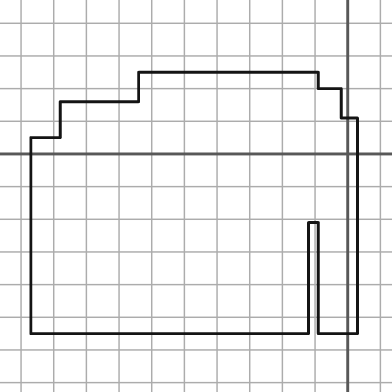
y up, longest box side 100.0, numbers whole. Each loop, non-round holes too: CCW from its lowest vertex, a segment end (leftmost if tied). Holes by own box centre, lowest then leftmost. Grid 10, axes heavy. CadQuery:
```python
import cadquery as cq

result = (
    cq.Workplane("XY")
    .moveTo(-97.0, -55.0)
    .lineTo(-12.0, -55.0)
    .lineTo(-12.0, -21.0)
    .lineTo(-9.0, -21.0)
    .lineTo(-9.0, -55.0)
    .lineTo(3.0, -55.0)
    .lineTo(3.0, 11.0)
    .lineTo(-2.0, 11.0)
    .lineTo(-2.0, 20.0)
    .lineTo(-9.0, 20.0)
    .lineTo(-9.0, 25.0)
    .lineTo(-64.0, 25.0)
    .lineTo(-64.0, 16.0)
    .lineTo(-88.0, 16.0)
    .lineTo(-88.0, 5.0)
    .lineTo(-97.0, 5.0)
    .close()
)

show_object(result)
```